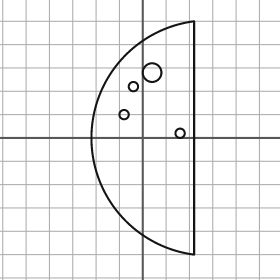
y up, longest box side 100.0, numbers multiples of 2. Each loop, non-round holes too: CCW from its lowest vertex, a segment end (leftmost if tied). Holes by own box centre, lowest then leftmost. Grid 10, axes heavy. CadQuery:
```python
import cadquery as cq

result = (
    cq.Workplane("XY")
    .moveTo(22.0, -50.0)
    .lineTo(22.0, 50.0)
    .threePointArc((-22.0, 0.0), (22.0, -50.0))
    .close()
    .moveTo(16.0, 2.0)
    .circle(2.0)
    .moveTo(-8.0, 10.0)
    .circle(2.0)
    .moveTo(-4.0, 22.0)
    .circle(2.0)
    .moveTo(4.0, 28.0)
    .circle(4.0)
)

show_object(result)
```